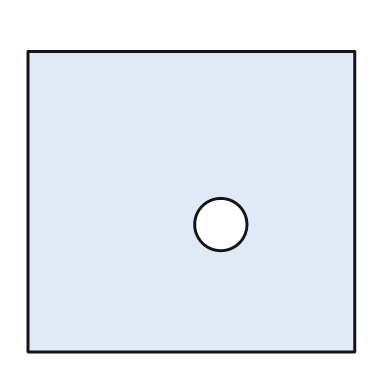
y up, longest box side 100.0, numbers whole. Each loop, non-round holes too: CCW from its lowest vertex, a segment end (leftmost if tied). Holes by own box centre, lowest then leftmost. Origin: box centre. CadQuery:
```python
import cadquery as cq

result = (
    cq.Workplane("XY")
    .moveTo(-50.0, -46.0)
    .lineTo(50.0, -46.0)
    .lineTo(50.0, 46.0)
    .lineTo(-50.0, 46.0)
    .close()
    .moveTo(9.0, -7.0)
    .circle(8.0)
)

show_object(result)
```